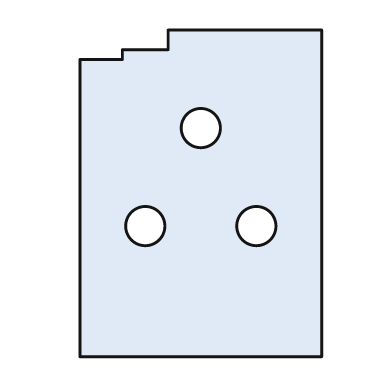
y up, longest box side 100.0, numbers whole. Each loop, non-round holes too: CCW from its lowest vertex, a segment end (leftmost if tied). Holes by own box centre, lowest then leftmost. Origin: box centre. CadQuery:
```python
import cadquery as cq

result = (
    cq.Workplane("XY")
    .moveTo(-37.0, -50.0)
    .lineTo(37.0, -50.0)
    .lineTo(37.0, 50.0)
    .lineTo(-10.0, 50.0)
    .lineTo(-10.0, 44.0)
    .lineTo(-24.0, 44.0)
    .lineTo(-24.0, 41.0)
    .lineTo(-37.0, 41.0)
    .close()
    .moveTo(-17.0, -10.0)
    .circle(6.0)
    .moveTo(17.0, -10.0)
    .circle(6.0)
    .moveTo(0.0, 20.0)
    .circle(6.0)
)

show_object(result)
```